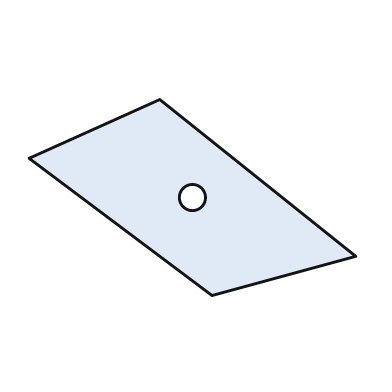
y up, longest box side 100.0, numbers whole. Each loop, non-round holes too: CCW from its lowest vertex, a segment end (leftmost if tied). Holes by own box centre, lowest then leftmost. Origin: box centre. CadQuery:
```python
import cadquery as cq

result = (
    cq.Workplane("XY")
    .moveTo(6.0, -30.0)
    .lineTo(50.0, -18.0)
    .lineTo(-10.0, 30.0)
    .lineTo(-50.0, 12.0)
    .close()
    .moveTo(0.0, 0.0)
    .circle(4.0)
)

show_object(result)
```